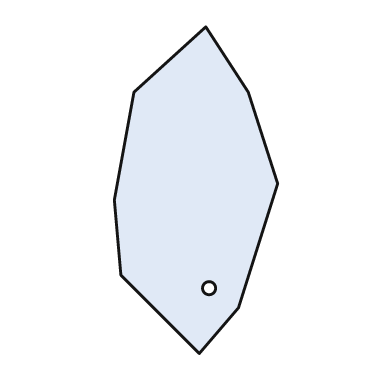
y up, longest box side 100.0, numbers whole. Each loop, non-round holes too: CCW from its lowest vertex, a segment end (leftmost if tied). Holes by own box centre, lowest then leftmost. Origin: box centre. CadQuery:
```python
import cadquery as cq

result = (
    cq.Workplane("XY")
    .moveTo(1.0, -50.0)
    .lineTo(13.0, -36.0)
    .lineTo(25.0, 2.0)
    .lineTo(16.0, 30.0)
    .lineTo(3.0, 50.0)
    .lineTo(-19.0, 30.0)
    .lineTo(-25.0, -3.0)
    .lineTo(-23.0, -26.0)
    .close()
    .moveTo(4.0, -30.0)
    .circle(2.0)
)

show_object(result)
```